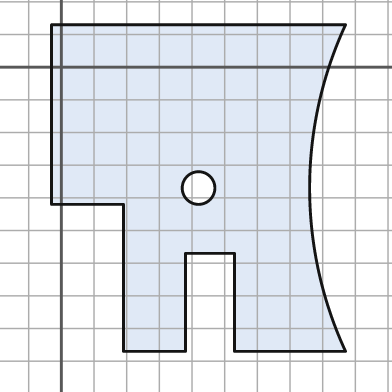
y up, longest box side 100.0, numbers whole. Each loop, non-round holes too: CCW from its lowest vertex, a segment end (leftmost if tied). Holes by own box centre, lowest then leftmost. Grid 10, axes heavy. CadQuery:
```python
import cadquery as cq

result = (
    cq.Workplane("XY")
    .moveTo(19.0, -87.0)
    .lineTo(38.0, -87.0)
    .lineTo(38.0, -57.0)
    .lineTo(53.0, -57.0)
    .lineTo(53.0, -87.0)
    .lineTo(87.0, -87.0)
    .threePointArc((76.0, -37.0), (87.0, 13.0))
    .lineTo(-3.0, 13.0)
    .lineTo(-3.0, -42.0)
    .lineTo(19.0, -42.0)
    .close()
    .moveTo(42.0, -37.0)
    .circle(5.0)
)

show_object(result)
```